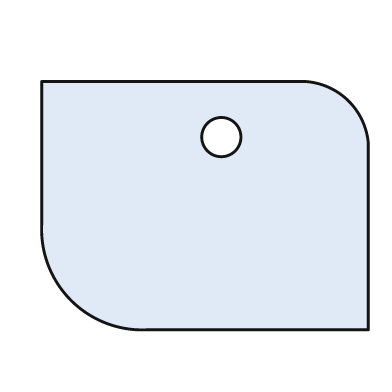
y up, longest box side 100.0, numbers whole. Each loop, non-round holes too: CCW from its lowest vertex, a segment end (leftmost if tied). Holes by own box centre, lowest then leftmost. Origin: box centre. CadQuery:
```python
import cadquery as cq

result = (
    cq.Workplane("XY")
    .moveTo(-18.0, -38.0)
    .lineTo(50.0, -38.0)
    .lineTo(50.0, 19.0)
    .threePointArc((44.0, 32.0), (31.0, 38.0))
    .lineTo(-50.0, 38.0)
    .lineTo(-50.0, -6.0)
    .threePointArc((-41.0, -29.0), (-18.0, -38.0))
    .close()
    .moveTo(5.0, 21.0)
    .circle(6.0)
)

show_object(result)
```